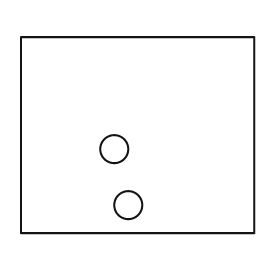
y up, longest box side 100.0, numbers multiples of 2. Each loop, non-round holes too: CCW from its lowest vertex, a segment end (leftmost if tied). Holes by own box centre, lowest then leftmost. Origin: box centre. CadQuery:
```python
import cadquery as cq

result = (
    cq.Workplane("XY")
    .moveTo(-50.0, -42.0)
    .lineTo(50.0, -42.0)
    .lineTo(50.0, 42.0)
    .lineTo(-50.0, 42.0)
    .close()
    .moveTo(-4.0, -30.0)
    .circle(6.0)
    .moveTo(-10.0, -6.0)
    .circle(6.0)
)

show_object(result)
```